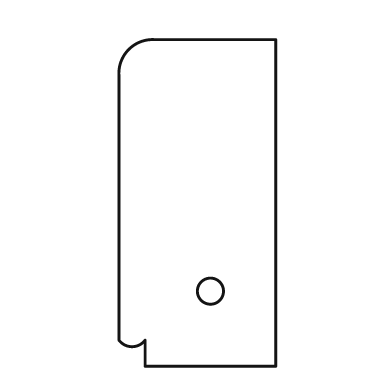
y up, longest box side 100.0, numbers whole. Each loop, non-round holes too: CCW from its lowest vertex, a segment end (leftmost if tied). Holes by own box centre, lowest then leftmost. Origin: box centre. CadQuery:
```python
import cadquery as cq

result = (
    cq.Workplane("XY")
    .moveTo(-16.0, -50.0)
    .lineTo(24.0, -50.0)
    .lineTo(24.0, 50.0)
    .lineTo(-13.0, 50.0)
    .threePointArc((-21.0, 47.0), (-24.0, 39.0))
    .lineTo(-24.0, -42.0)
    .threePointArc((-20.0, -44.0), (-16.0, -42.0))
    .close()
    .moveTo(4.0, -27.0)
    .circle(4.0)
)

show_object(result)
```